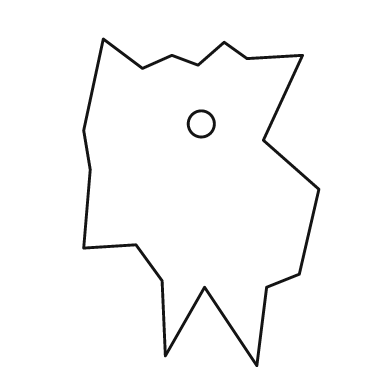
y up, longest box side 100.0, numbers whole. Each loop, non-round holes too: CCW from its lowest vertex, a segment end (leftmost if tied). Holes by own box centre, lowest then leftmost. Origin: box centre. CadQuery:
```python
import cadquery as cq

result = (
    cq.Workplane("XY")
    .moveTo(17.0, -50.0)
    .lineTo(20.0, -26.0)
    .lineTo(30.0, -22.0)
    .lineTo(36.0, 4.0)
    .lineTo(19.0, 19.0)
    .lineTo(31.0, 45.0)
    .lineTo(14.0, 44.0)
    .lineTo(7.0, 49.0)
    .lineTo(-1.0, 42.0)
    .lineTo(-9.0, 45.0)
    .lineTo(-18.0, 41.0)
    .lineTo(-30.0, 50.0)
    .lineTo(-36.0, 22.0)
    .lineTo(-34.0, 10.0)
    .lineTo(-36.0, -14.0)
    .lineTo(-20.0, -13.0)
    .lineTo(-12.0, -24.0)
    .lineTo(-11.0, -47.0)
    .lineTo(1.0, -26.0)
    .close()
    .moveTo(0.0, 24.0)
    .circle(4.0)
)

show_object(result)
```